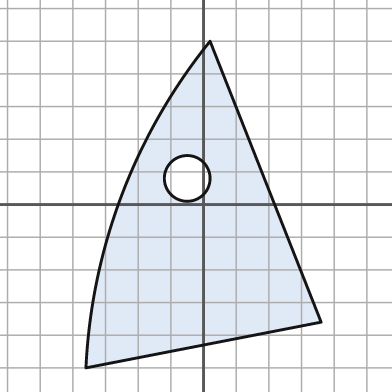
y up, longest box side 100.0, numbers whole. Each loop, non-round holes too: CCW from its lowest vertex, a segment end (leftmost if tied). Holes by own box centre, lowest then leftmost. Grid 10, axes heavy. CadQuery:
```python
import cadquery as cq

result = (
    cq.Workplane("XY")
    .moveTo(-36.0, -50.0)
    .lineTo(36.0, -36.0)
    .lineTo(2.0, 50.0)
    .threePointArc((-25.0, 3.0), (-36.0, -50.0))
    .close()
    .moveTo(-5.0, 8.0)
    .circle(7.0)
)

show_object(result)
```